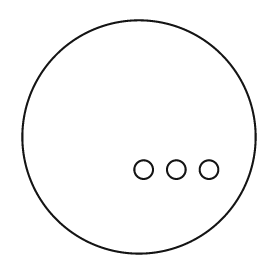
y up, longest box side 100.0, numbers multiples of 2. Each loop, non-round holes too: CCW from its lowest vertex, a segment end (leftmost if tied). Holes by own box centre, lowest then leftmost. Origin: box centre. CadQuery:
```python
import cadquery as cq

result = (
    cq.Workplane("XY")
    .moveTo(0.0, 0.0)
    .circle(50.0)
    .moveTo(2.0, -14.0)
    .circle(4.0)
    .moveTo(16.0, -14.0)
    .circle(4.0)
    .moveTo(30.0, -14.0)
    .circle(4.0)
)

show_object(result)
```